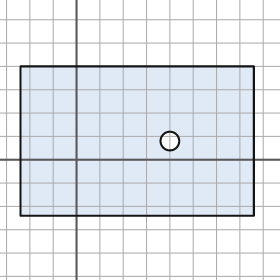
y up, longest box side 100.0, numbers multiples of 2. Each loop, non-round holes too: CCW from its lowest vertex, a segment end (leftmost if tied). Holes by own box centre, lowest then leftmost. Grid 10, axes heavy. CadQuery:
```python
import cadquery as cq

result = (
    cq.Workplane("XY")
    .moveTo(-24.0, -24.0)
    .lineTo(76.0, -24.0)
    .lineTo(76.0, 40.0)
    .lineTo(-24.0, 40.0)
    .close()
    .moveTo(40.0, 8.0)
    .circle(4.0)
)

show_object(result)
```